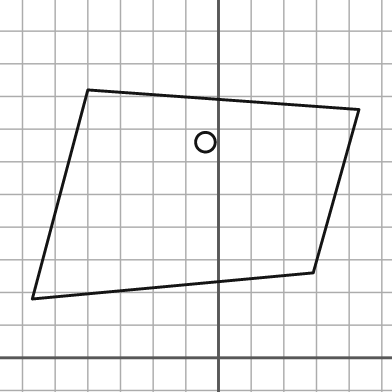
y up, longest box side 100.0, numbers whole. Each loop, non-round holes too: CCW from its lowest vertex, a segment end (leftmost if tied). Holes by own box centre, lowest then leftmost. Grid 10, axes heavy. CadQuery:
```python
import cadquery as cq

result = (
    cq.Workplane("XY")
    .moveTo(-57.0, 18.0)
    .lineTo(29.0, 26.0)
    .lineTo(43.0, 76.0)
    .lineTo(-40.0, 82.0)
    .close()
    .moveTo(-4.0, 66.0)
    .circle(3.0)
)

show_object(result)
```